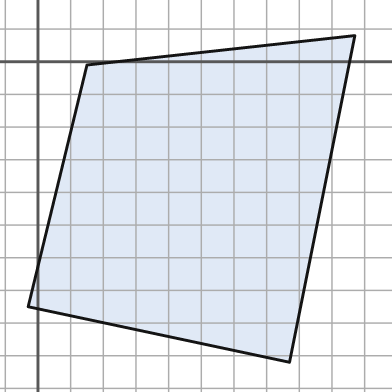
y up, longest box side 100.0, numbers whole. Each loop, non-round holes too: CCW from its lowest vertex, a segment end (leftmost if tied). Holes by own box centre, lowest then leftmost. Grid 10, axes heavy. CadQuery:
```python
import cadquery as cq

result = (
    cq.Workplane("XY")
    .moveTo(77.0, -92.0)
    .lineTo(97.0, 8.0)
    .lineTo(15.0, -1.0)
    .lineTo(-3.0, -75.0)
    .close()
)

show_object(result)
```